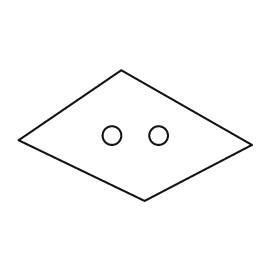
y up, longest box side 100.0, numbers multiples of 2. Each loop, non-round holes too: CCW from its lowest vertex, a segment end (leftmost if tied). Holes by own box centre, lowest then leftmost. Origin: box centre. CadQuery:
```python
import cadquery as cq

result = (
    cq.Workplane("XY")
    .moveTo(4.0, -28.0)
    .lineTo(50.0, -4.0)
    .lineTo(-6.0, 28.0)
    .lineTo(-50.0, -2.0)
    .close()
    .moveTo(-10.0, 0.0)
    .circle(4.0)
    .moveTo(10.0, 0.0)
    .circle(4.0)
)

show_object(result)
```